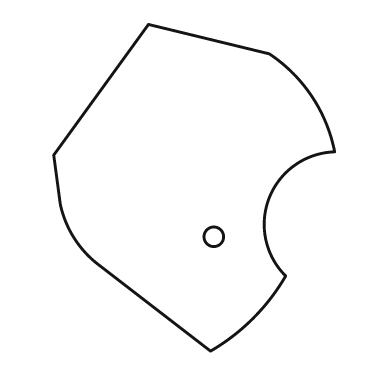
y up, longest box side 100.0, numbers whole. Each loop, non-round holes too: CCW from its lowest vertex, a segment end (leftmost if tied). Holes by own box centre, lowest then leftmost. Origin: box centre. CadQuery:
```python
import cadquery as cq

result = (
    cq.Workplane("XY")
    .moveTo(5.0, -50.0)
    .threePointArc((18.0, -40.0), (28.0, -27.0))
    .threePointArc((23.0, -3.0), (43.0, 11.0))
    .threePointArc((36.0, 28.0), (23.0, 41.0))
    .lineTo(-14.0, 50.0)
    .lineTo(-43.0, 10.0)
    .lineTo(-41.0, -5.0)
    .threePointArc((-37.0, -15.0), (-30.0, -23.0))
    .close()
    .moveTo(6.0, -15.0)
    .circle(3.0)
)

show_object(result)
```